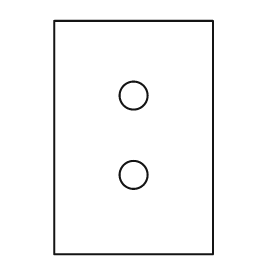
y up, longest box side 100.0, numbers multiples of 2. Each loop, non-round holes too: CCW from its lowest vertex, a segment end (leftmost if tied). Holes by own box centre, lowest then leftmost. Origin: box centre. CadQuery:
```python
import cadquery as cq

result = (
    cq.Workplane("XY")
    .moveTo(-34.0, -50.0)
    .lineTo(34.0, -50.0)
    .lineTo(34.0, 50.0)
    .lineTo(-34.0, 50.0)
    .close()
    .moveTo(0.0, -16.0)
    .circle(6.0)
    .moveTo(0.0, 18.0)
    .circle(6.0)
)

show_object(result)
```